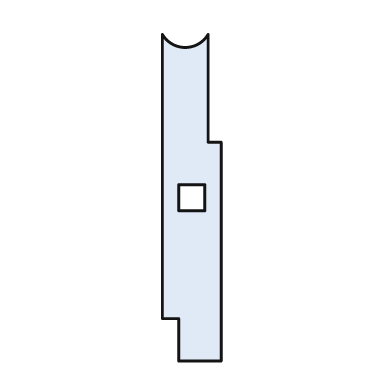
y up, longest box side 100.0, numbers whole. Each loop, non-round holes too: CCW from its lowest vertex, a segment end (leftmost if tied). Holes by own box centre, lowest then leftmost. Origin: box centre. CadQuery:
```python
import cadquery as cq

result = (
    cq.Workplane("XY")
    .moveTo(-4.0, -50.0)
    .lineTo(9.0, -50.0)
    .lineTo(9.0, 17.0)
    .lineTo(5.0, 17.0)
    .lineTo(5.0, 50.0)
    .threePointArc((-2.0, 46.0), (-9.0, 50.0))
    .lineTo(-9.0, -37.0)
    .lineTo(-4.0, -37.0)
    .close()
    .moveTo(-4.0, -4.0)
    .lineTo(4.0, -4.0)
    .lineTo(4.0, 4.0)
    .lineTo(-4.0, 4.0)
    .close()
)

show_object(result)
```